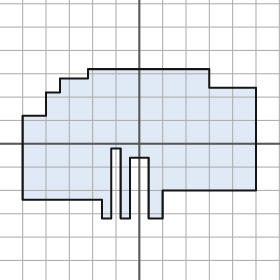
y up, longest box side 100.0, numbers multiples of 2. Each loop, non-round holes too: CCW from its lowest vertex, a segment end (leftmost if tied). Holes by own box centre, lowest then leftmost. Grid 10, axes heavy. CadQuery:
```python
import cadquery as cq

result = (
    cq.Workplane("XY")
    .moveTo(-16.0, -32.0)
    .lineTo(-12.0, -32.0)
    .lineTo(-12.0, -2.0)
    .lineTo(-8.0, -2.0)
    .lineTo(-8.0, -32.0)
    .lineTo(-4.0, -32.0)
    .lineTo(-4.0, -6.0)
    .lineTo(4.0, -6.0)
    .lineTo(4.0, -32.0)
    .lineTo(10.0, -32.0)
    .lineTo(10.0, -20.0)
    .lineTo(50.0, -20.0)
    .lineTo(50.0, 24.0)
    .lineTo(30.0, 24.0)
    .lineTo(30.0, 32.0)
    .lineTo(-22.0, 32.0)
    .lineTo(-22.0, 28.0)
    .lineTo(-34.0, 28.0)
    .lineTo(-34.0, 22.0)
    .lineTo(-40.0, 22.0)
    .lineTo(-40.0, 12.0)
    .lineTo(-50.0, 12.0)
    .lineTo(-50.0, -24.0)
    .lineTo(-16.0, -24.0)
    .close()
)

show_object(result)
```